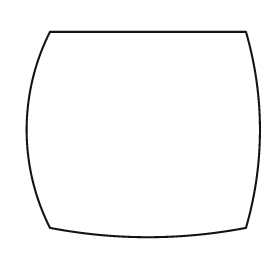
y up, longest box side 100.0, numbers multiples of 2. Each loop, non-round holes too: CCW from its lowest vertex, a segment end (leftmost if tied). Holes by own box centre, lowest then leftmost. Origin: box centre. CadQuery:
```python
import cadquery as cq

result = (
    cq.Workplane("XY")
    .moveTo(-40.0, -40.0)
    .threePointArc((2.0, -44.0), (44.0, -40.0))
    .threePointArc((50.0, 2.0), (44.0, 44.0))
    .lineTo(-40.0, 44.0)
    .threePointArc((-50.0, 2.0), (-40.0, -40.0))
    .close()
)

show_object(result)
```